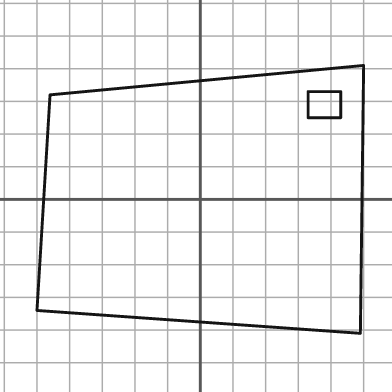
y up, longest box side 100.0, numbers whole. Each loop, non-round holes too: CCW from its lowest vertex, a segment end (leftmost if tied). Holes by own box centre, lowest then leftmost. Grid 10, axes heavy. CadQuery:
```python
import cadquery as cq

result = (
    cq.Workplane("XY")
    .moveTo(49.0, -41.0)
    .lineTo(50.0, 41.0)
    .lineTo(-46.0, 32.0)
    .lineTo(-50.0, -34.0)
    .close()
    .moveTo(33.0, 25.0)
    .lineTo(43.0, 25.0)
    .lineTo(43.0, 33.0)
    .lineTo(33.0, 33.0)
    .close()
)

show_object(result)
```